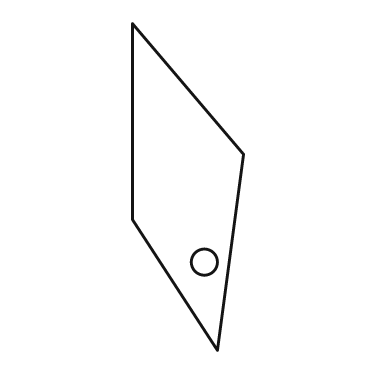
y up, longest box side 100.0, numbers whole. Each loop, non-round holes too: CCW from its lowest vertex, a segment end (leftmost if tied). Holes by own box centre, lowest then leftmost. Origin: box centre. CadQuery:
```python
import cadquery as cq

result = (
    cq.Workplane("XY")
    .moveTo(9.0, -50.0)
    .lineTo(17.0, 10.0)
    .lineTo(-17.0, 50.0)
    .lineTo(-17.0, -10.0)
    .close()
    .moveTo(5.0, -23.0)
    .circle(4.0)
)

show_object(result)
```